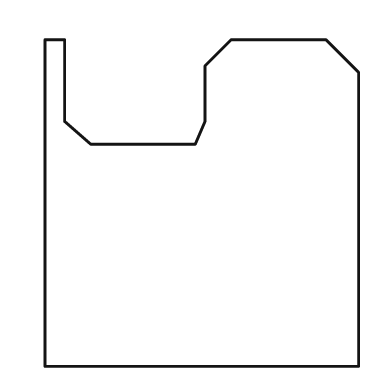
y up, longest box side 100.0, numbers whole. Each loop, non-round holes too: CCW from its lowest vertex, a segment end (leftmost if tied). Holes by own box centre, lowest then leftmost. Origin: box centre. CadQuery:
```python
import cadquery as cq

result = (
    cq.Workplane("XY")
    .moveTo(-48.0, -50.0)
    .lineTo(48.0, -50.0)
    .lineTo(48.0, 40.0)
    .lineTo(38.0, 50.0)
    .lineTo(9.0, 50.0)
    .lineTo(1.0, 42.0)
    .lineTo(1.0, 25.0)
    .lineTo(-2.0, 18.0)
    .lineTo(-34.0, 18.0)
    .lineTo(-42.0, 25.0)
    .lineTo(-42.0, 50.0)
    .lineTo(-48.0, 50.0)
    .close()
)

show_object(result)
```